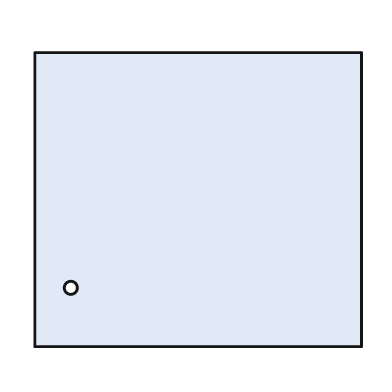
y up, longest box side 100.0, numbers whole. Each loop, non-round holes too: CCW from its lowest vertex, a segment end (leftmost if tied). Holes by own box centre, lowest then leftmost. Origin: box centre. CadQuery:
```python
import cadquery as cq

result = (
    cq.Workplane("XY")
    .moveTo(-50.0, -45.0)
    .lineTo(50.0, -45.0)
    .lineTo(50.0, 45.0)
    .lineTo(-50.0, 45.0)
    .close()
    .moveTo(-39.0, -27.0)
    .circle(2.0)
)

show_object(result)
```